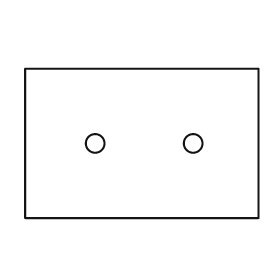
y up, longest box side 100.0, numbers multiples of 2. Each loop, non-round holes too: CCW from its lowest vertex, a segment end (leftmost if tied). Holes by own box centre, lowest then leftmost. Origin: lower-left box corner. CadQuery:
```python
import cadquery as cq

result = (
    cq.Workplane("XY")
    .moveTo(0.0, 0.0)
    .lineTo(100.0, 0.0)
    .lineTo(100.0, 64.0)
    .lineTo(0.0, 64.0)
    .close()
    .moveTo(30.0, 32.0)
    .circle(4.0)
    .moveTo(72.0, 32.0)
    .circle(4.0)
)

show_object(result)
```